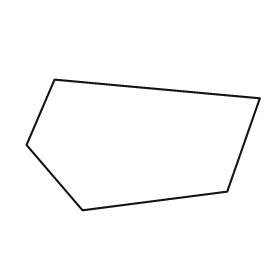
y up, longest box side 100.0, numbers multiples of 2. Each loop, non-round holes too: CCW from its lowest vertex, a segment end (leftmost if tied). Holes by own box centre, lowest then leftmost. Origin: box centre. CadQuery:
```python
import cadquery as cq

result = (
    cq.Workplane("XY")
    .moveTo(-26.0, -28.0)
    .lineTo(36.0, -20.0)
    .lineTo(50.0, 20.0)
    .lineTo(-38.0, 28.0)
    .lineTo(-50.0, 0.0)
    .close()
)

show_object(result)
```